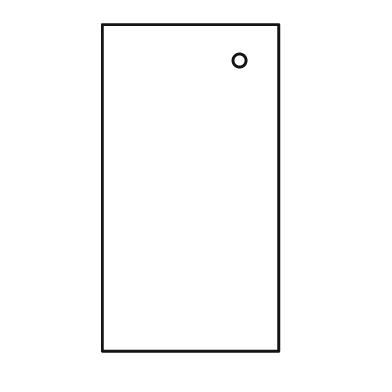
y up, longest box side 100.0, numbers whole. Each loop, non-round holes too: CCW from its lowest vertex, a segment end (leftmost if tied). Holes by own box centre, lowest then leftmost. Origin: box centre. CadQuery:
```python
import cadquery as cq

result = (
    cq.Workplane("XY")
    .moveTo(-27.0, -50.0)
    .lineTo(27.0, -50.0)
    .lineTo(27.0, 50.0)
    .lineTo(-27.0, 50.0)
    .close()
    .moveTo(15.0, 39.0)
    .circle(2.0)
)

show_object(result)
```